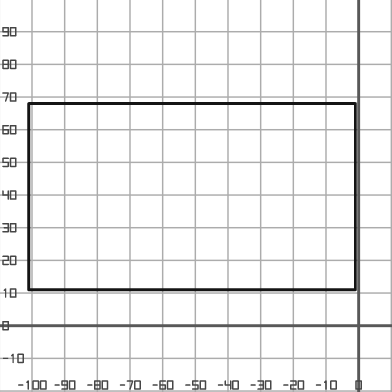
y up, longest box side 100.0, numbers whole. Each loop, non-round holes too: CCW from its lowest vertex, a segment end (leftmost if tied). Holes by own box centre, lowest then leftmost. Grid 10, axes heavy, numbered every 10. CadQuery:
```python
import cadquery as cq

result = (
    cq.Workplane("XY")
    .moveTo(-101.0, 11.0)
    .lineTo(-1.0, 11.0)
    .lineTo(-1.0, 68.0)
    .lineTo(-101.0, 68.0)
    .close()
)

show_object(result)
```